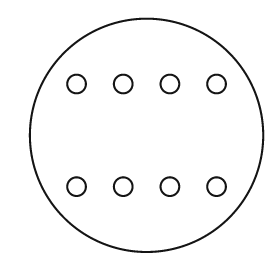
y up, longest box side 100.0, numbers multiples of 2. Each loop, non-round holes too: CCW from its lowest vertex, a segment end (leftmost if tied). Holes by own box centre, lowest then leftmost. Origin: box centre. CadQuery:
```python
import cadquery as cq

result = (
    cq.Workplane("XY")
    .moveTo(0.0, 0.0)
    .circle(50.0)
    .moveTo(-30.0, -22.0)
    .circle(4.0)
    .moveTo(-10.0, -22.0)
    .circle(4.0)
    .moveTo(10.0, -22.0)
    .circle(4.0)
    .moveTo(30.0, -22.0)
    .circle(4.0)
    .moveTo(-30.0, 22.0)
    .circle(4.0)
    .moveTo(-10.0, 22.0)
    .circle(4.0)
    .moveTo(10.0, 22.0)
    .circle(4.0)
    .moveTo(30.0, 22.0)
    .circle(4.0)
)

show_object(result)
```